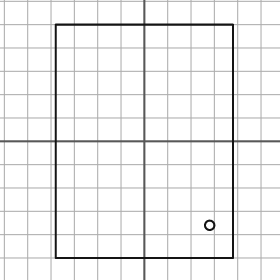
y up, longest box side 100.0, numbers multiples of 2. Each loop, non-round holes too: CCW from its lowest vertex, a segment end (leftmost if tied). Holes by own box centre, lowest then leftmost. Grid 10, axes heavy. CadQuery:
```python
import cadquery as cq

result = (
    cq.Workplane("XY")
    .moveTo(-38.0, -50.0)
    .lineTo(38.0, -50.0)
    .lineTo(38.0, 50.0)
    .lineTo(-38.0, 50.0)
    .close()
    .moveTo(28.0, -36.0)
    .circle(2.0)
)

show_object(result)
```